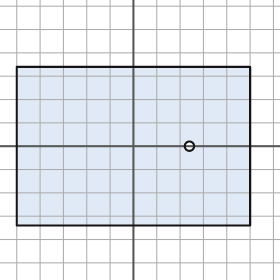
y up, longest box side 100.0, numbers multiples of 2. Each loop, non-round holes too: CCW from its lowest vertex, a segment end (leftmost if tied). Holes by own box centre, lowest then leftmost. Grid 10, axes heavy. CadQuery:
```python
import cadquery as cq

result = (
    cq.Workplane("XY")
    .moveTo(-50.0, -34.0)
    .lineTo(50.0, -34.0)
    .lineTo(50.0, 34.0)
    .lineTo(-50.0, 34.0)
    .close()
    .moveTo(24.0, 0.0)
    .circle(2.0)
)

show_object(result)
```